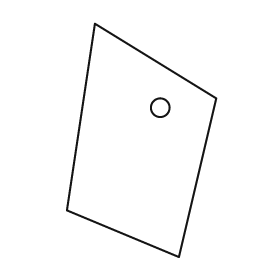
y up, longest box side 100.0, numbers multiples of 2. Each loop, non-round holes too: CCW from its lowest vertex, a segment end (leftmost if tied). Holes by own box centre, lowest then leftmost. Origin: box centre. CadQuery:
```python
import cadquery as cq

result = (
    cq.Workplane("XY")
    .moveTo(16.0, -50.0)
    .lineTo(32.0, 18.0)
    .lineTo(-20.0, 50.0)
    .lineTo(-32.0, -30.0)
    .close()
    .moveTo(8.0, 14.0)
    .circle(4.0)
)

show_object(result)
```